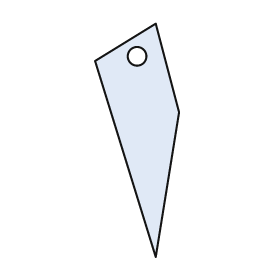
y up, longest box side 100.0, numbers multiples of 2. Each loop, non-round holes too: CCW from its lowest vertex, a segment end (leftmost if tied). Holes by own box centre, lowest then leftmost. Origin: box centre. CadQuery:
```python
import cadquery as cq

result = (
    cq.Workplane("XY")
    .moveTo(8.0, -50.0)
    .lineTo(18.0, 12.0)
    .lineTo(8.0, 50.0)
    .lineTo(-18.0, 34.0)
    .close()
    .moveTo(0.0, 36.0)
    .circle(4.0)
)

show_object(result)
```